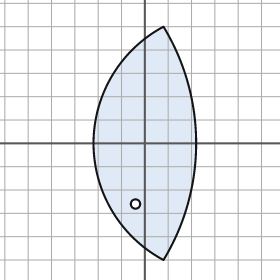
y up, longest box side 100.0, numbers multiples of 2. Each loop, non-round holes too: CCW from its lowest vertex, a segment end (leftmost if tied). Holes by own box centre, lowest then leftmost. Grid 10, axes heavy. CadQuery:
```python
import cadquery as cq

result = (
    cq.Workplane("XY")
    .moveTo(8.0, -50.0)
    .threePointArc((22.0, 0.0), (8.0, 50.0))
    .threePointArc((-22.0, 0.0), (8.0, -50.0))
    .close()
    .moveTo(-4.0, -26.0)
    .circle(2.0)
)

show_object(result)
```